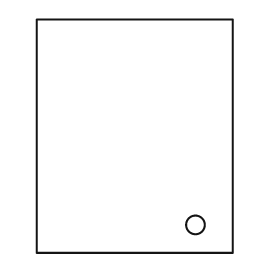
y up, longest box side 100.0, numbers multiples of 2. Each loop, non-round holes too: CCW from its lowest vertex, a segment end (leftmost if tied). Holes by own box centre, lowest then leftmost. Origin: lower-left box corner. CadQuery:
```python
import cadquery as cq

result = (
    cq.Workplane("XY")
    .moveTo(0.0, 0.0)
    .lineTo(84.0, 0.0)
    .lineTo(84.0, 100.0)
    .lineTo(0.0, 100.0)
    .close()
    .moveTo(68.0, 12.0)
    .circle(4.0)
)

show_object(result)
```